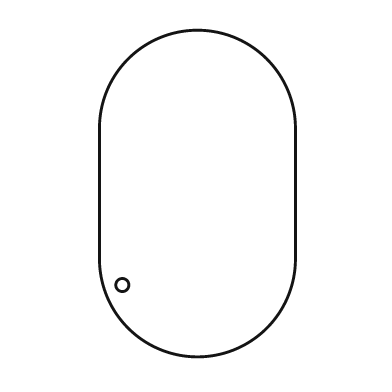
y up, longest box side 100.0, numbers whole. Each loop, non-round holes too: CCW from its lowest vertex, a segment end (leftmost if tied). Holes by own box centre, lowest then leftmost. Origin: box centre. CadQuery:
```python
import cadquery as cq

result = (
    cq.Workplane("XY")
    .moveTo(-30.0, -20.0)
    .threePointArc((0.0, -50.0), (30.0, -20.0))
    .lineTo(30.0, 20.0)
    .threePointArc((0.0, 50.0), (-30.0, 20.0))
    .close()
    .moveTo(-23.0, -28.0)
    .circle(2.0)
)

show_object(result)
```